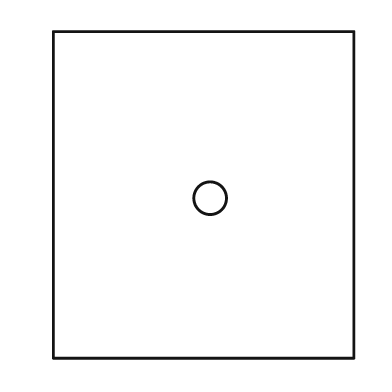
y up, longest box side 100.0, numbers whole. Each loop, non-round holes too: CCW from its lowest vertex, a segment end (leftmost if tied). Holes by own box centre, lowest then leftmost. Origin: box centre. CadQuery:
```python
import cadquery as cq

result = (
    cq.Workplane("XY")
    .moveTo(-46.0, -50.0)
    .lineTo(46.0, -50.0)
    .lineTo(46.0, 50.0)
    .lineTo(-46.0, 50.0)
    .close()
    .moveTo(2.0, -1.0)
    .circle(5.0)
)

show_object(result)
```